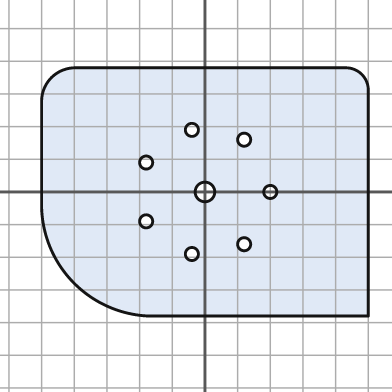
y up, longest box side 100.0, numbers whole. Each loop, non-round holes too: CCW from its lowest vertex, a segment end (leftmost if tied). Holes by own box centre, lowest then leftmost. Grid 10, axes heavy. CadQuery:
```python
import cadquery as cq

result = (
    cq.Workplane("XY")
    .moveTo(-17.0, -38.0)
    .lineTo(50.0, -38.0)
    .lineTo(50.0, 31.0)
    .threePointArc((48.0, 36.0), (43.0, 38.0))
    .lineTo(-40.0, 38.0)
    .threePointArc((-47.0, 35.0), (-50.0, 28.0))
    .lineTo(-50.0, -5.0)
    .threePointArc((-40.0, -28.0), (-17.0, -38.0))
    .close()
    .moveTo(-4.0, -19.0)
    .circle(2.0)
    .moveTo(12.0, -16.0)
    .circle(2.0)
    .moveTo(-18.0, -9.0)
    .circle(2.0)
    .moveTo(0.0, 0.0)
    .circle(3.0)
    .moveTo(20.0, 0.0)
    .circle(2.0)
    .moveTo(-18.0, 9.0)
    .circle(2.0)
    .moveTo(12.0, 16.0)
    .circle(2.0)
    .moveTo(-4.0, 19.0)
    .circle(2.0)
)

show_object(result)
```